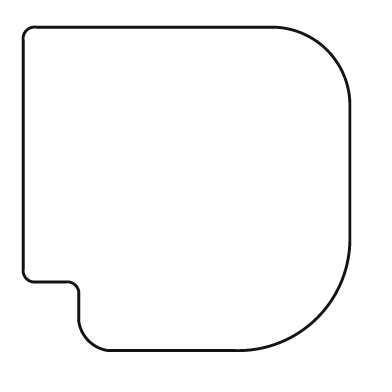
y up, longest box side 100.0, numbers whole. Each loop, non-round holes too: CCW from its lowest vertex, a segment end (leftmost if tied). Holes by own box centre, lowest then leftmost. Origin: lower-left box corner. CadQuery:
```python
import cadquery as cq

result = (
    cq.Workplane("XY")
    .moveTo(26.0, 0.0)
    .lineTo(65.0, 0.0)
    .threePointArc((90.0, 10.0), (100.0, 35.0))
    .lineTo(100.0, 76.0)
    .threePointArc((93.0, 92.0), (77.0, 99.0))
    .lineTo(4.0, 99.0)
    .threePointArc((1.0, 98.0), (0.0, 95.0))
    .lineTo(0.0, 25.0)
    .threePointArc((1.0, 22.0), (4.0, 21.0))
    .lineTo(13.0, 21.0)
    .threePointArc((16.0, 20.0), (17.0, 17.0))
    .lineTo(17.0, 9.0)
    .threePointArc((20.0, 3.0), (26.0, 0.0))
    .close()
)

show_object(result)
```